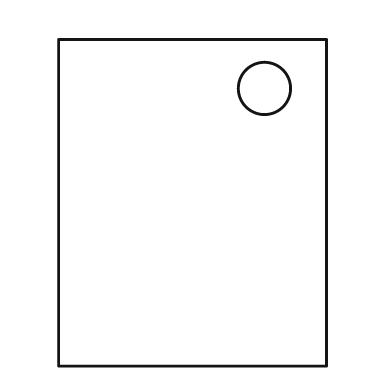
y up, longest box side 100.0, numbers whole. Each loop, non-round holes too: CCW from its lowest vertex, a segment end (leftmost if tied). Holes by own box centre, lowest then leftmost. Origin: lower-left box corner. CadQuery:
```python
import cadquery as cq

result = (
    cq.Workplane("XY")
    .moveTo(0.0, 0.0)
    .lineTo(82.0, 0.0)
    .lineTo(82.0, 100.0)
    .lineTo(0.0, 100.0)
    .close()
    .moveTo(63.0, 85.0)
    .circle(8.0)
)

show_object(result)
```